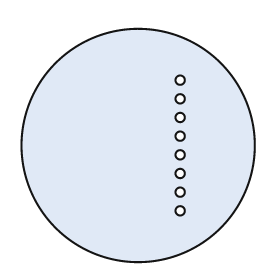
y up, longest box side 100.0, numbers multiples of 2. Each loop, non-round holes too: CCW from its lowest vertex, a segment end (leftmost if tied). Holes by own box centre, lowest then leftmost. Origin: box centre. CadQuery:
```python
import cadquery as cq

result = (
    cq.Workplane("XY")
    .moveTo(0.0, 0.0)
    .circle(50.0)
    .moveTo(18.0, -28.0)
    .circle(2.0)
    .moveTo(18.0, -20.0)
    .circle(2.0)
    .moveTo(18.0, -12.0)
    .circle(2.0)
    .moveTo(18.0, -4.0)
    .circle(2.0)
    .moveTo(18.0, 4.0)
    .circle(2.0)
    .moveTo(18.0, 12.0)
    .circle(2.0)
    .moveTo(18.0, 20.0)
    .circle(2.0)
    .moveTo(18.0, 28.0)
    .circle(2.0)
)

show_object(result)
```